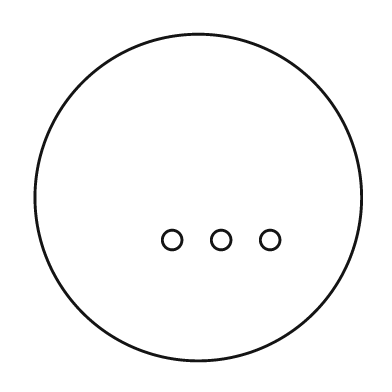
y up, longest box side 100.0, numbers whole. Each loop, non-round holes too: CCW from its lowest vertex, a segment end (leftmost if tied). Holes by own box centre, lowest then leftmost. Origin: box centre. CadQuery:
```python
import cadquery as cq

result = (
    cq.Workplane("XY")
    .moveTo(0.0, 0.0)
    .circle(50.0)
    .moveTo(-8.0, -13.0)
    .circle(3.0)
    .moveTo(7.0, -13.0)
    .circle(3.0)
    .moveTo(22.0, -13.0)
    .circle(3.0)
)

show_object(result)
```